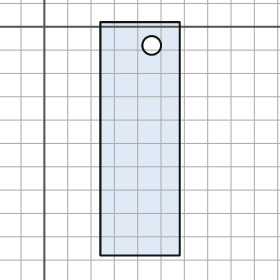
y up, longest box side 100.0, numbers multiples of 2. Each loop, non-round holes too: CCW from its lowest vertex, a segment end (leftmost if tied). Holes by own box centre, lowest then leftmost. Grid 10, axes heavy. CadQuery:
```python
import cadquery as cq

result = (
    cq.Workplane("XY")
    .moveTo(24.0, -98.0)
    .lineTo(58.0, -98.0)
    .lineTo(58.0, 2.0)
    .lineTo(24.0, 2.0)
    .close()
    .moveTo(46.0, -8.0)
    .circle(4.0)
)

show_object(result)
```